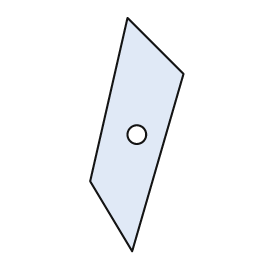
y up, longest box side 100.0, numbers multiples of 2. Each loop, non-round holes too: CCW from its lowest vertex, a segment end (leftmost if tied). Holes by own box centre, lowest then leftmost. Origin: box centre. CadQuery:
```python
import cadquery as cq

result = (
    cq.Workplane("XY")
    .moveTo(-2.0, -50.0)
    .lineTo(20.0, 26.0)
    .lineTo(-4.0, 50.0)
    .lineTo(-20.0, -20.0)
    .close()
    .moveTo(0.0, 0.0)
    .circle(4.0)
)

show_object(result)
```